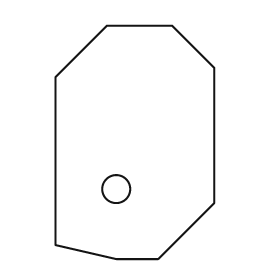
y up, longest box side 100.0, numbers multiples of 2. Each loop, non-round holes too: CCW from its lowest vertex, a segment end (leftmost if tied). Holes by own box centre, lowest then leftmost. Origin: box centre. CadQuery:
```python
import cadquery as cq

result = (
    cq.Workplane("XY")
    .moveTo(-8.0, -50.0)
    .lineTo(10.0, -50.0)
    .lineTo(34.0, -26.0)
    .lineTo(34.0, 32.0)
    .lineTo(16.0, 50.0)
    .lineTo(-12.0, 50.0)
    .lineTo(-34.0, 28.0)
    .lineTo(-34.0, -44.0)
    .close()
    .moveTo(-8.0, -20.0)
    .circle(6.0)
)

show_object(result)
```